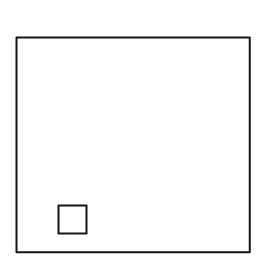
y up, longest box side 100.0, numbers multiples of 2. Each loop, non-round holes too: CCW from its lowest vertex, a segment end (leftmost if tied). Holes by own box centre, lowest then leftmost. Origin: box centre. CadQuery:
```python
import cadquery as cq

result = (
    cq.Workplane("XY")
    .moveTo(-50.0, -46.0)
    .lineTo(50.0, -46.0)
    .lineTo(50.0, 46.0)
    .lineTo(-50.0, 46.0)
    .close()
    .moveTo(-32.0, -38.0)
    .lineTo(-20.0, -38.0)
    .lineTo(-20.0, -26.0)
    .lineTo(-32.0, -26.0)
    .close()
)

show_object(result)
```